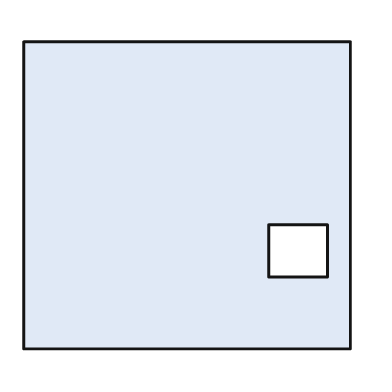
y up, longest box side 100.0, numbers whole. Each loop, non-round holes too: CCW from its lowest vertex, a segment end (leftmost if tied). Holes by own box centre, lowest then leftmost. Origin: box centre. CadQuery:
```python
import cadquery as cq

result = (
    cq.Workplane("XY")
    .moveTo(-50.0, -47.0)
    .lineTo(50.0, -47.0)
    .lineTo(50.0, 47.0)
    .lineTo(-50.0, 47.0)
    .close()
    .moveTo(25.0, -25.0)
    .lineTo(43.0, -25.0)
    .lineTo(43.0, -9.0)
    .lineTo(25.0, -9.0)
    .close()
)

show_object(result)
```